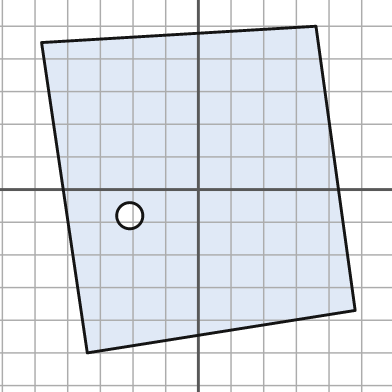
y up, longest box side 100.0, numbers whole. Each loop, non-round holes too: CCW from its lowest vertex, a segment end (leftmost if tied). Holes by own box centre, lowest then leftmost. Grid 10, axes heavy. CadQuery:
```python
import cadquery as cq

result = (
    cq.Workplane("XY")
    .moveTo(-34.0, -50.0)
    .lineTo(48.0, -37.0)
    .lineTo(36.0, 50.0)
    .lineTo(-48.0, 45.0)
    .close()
    .moveTo(-21.0, -8.0)
    .circle(4.0)
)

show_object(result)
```